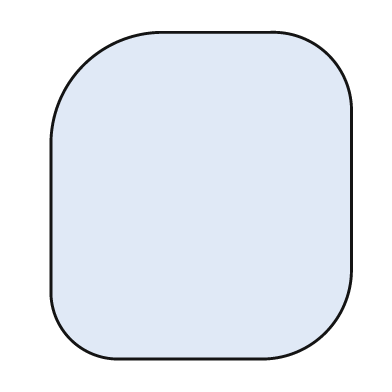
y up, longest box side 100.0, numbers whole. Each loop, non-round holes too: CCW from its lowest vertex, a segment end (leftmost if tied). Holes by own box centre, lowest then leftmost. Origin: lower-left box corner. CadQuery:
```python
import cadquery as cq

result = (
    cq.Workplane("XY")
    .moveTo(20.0, 0.0)
    .lineTo(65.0, 0.0)
    .threePointArc((84.0, 8.0), (92.0, 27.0))
    .lineTo(92.0, 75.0)
    .threePointArc((85.0, 93.0), (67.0, 100.0))
    .lineTo(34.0, 100.0)
    .threePointArc((10.0, 90.0), (0.0, 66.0))
    .lineTo(0.0, 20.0)
    .threePointArc((6.0, 6.0), (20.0, 0.0))
    .close()
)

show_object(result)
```